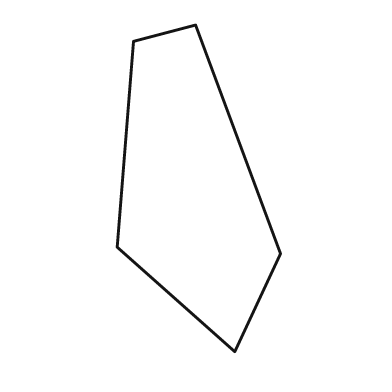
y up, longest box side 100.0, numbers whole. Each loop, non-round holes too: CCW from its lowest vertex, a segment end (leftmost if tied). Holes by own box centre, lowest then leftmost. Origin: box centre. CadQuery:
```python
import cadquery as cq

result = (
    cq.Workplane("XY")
    .moveTo(11.0, -50.0)
    .lineTo(25.0, -20.0)
    .lineTo(-1.0, 50.0)
    .lineTo(-20.0, 45.0)
    .lineTo(-25.0, -18.0)
    .close()
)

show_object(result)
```